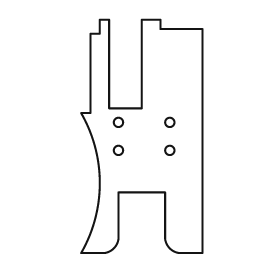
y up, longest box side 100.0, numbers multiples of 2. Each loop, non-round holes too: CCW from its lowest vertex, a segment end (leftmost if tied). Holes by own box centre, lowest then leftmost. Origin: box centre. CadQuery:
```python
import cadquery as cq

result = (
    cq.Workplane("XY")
    .moveTo(-26.0, -50.0)
    .lineTo(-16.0, -50.0)
    .threePointArc((-12.0, -48.0), (-10.0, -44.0))
    .lineTo(-10.0, -24.0)
    .lineTo(10.0, -24.0)
    .lineTo(10.0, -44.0)
    .threePointArc((12.0, -48.0), (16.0, -50.0))
    .lineTo(26.0, -50.0)
    .lineTo(26.0, 46.0)
    .lineTo(8.0, 46.0)
    .lineTo(8.0, 50.0)
    .lineTo(0.0, 50.0)
    .lineTo(0.0, 12.0)
    .lineTo(-14.0, 12.0)
    .lineTo(-14.0, 50.0)
    .lineTo(-18.0, 50.0)
    .lineTo(-18.0, 44.0)
    .lineTo(-22.0, 44.0)
    .lineTo(-22.0, 10.0)
    .lineTo(-26.0, 10.0)
    .threePointArc((-18.0, -20.0), (-26.0, -50.0))
    .close()
    .moveTo(-10.0, -6.0)
    .circle(2.0)
    .moveTo(12.0, -6.0)
    .circle(2.0)
    .moveTo(-10.0, 6.0)
    .circle(2.0)
    .moveTo(12.0, 6.0)
    .circle(2.0)
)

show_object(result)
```